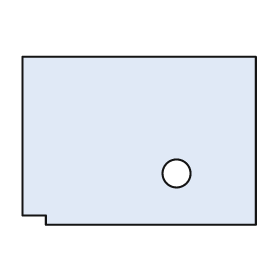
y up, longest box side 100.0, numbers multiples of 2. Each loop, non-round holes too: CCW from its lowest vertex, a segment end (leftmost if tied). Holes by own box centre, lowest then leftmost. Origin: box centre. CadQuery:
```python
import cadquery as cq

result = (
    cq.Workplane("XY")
    .moveTo(-40.0, -36.0)
    .lineTo(50.0, -36.0)
    .lineTo(50.0, 36.0)
    .lineTo(-50.0, 36.0)
    .lineTo(-50.0, -32.0)
    .lineTo(-40.0, -32.0)
    .close()
    .moveTo(16.0, -14.0)
    .circle(6.0)
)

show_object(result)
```